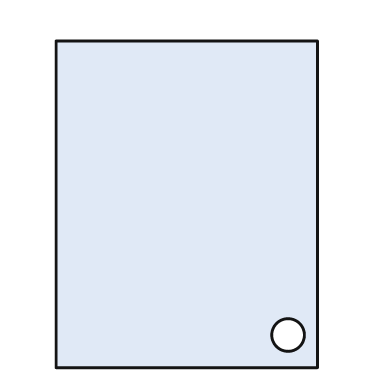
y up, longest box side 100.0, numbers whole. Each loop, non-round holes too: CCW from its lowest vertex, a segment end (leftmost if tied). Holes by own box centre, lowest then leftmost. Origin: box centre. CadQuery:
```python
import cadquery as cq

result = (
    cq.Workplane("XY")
    .moveTo(-40.0, -50.0)
    .lineTo(40.0, -50.0)
    .lineTo(40.0, 50.0)
    .lineTo(-40.0, 50.0)
    .close()
    .moveTo(31.0, -40.0)
    .circle(5.0)
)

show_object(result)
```